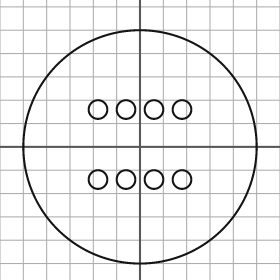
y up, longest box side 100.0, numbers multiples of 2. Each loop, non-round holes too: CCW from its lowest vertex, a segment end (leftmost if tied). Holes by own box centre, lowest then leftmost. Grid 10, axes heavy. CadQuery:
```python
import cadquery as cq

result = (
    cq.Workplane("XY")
    .moveTo(0.0, 0.0)
    .circle(50.0)
    .moveTo(-18.0, -14.0)
    .circle(4.0)
    .moveTo(-6.0, -14.0)
    .circle(4.0)
    .moveTo(6.0, -14.0)
    .circle(4.0)
    .moveTo(18.0, -14.0)
    .circle(4.0)
    .moveTo(-18.0, 16.0)
    .circle(4.0)
    .moveTo(-6.0, 16.0)
    .circle(4.0)
    .moveTo(6.0, 16.0)
    .circle(4.0)
    .moveTo(18.0, 16.0)
    .circle(4.0)
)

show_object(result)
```